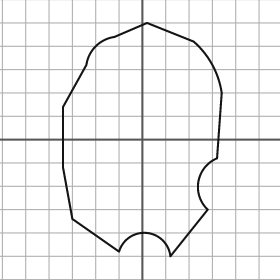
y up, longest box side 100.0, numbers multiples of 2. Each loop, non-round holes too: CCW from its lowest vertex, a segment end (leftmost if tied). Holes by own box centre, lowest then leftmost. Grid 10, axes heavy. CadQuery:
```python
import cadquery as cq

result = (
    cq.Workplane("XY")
    .moveTo(12.0, -50.0)
    .lineTo(28.0, -30.0)
    .threePointArc((24.0, -18.0), (32.0, -8.0))
    .lineTo(34.0, 20.0)
    .threePointArc((30.0, 32.0), (22.0, 42.0))
    .lineTo(2.0, 50.0)
    .lineTo(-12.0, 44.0)
    .threePointArc((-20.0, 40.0), (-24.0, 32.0))
    .lineTo(-34.0, 14.0)
    .lineTo(-34.0, -12.0)
    .lineTo(-30.0, -34.0)
    .lineTo(-10.0, -48.0)
    .threePointArc((2.0, -40.0), (12.0, -50.0))
    .close()
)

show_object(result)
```